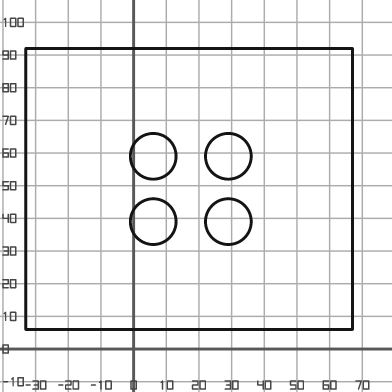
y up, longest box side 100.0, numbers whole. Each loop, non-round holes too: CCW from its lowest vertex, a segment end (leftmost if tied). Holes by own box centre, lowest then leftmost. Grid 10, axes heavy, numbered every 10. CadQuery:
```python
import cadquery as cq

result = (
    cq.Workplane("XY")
    .moveTo(-33.0, 6.0)
    .lineTo(67.0, 6.0)
    .lineTo(67.0, 92.0)
    .lineTo(-33.0, 92.0)
    .close()
    .moveTo(6.0, 39.0)
    .circle(7.0)
    .moveTo(29.0, 39.0)
    .circle(7.0)
    .moveTo(6.0, 59.0)
    .circle(7.0)
    .moveTo(29.0, 59.0)
    .circle(7.0)
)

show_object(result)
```